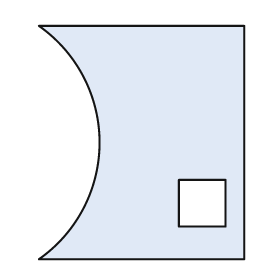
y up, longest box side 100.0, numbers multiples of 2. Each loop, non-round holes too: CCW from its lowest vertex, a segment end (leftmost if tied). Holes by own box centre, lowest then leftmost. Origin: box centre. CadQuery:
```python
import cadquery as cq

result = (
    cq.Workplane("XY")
    .moveTo(-44.0, -50.0)
    .lineTo(44.0, -50.0)
    .lineTo(44.0, 50.0)
    .lineTo(-44.0, 50.0)
    .threePointArc((-18.0, 0.0), (-44.0, -50.0))
    .close()
    .moveTo(16.0, -36.0)
    .lineTo(36.0, -36.0)
    .lineTo(36.0, -16.0)
    .lineTo(16.0, -16.0)
    .close()
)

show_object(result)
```